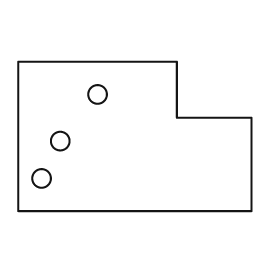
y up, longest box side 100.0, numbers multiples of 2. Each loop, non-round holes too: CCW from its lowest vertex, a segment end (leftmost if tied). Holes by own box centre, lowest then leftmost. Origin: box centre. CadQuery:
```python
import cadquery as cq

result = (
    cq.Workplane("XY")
    .moveTo(-50.0, -32.0)
    .lineTo(50.0, -32.0)
    .lineTo(50.0, 8.0)
    .lineTo(18.0, 8.0)
    .lineTo(18.0, 32.0)
    .lineTo(-50.0, 32.0)
    .close()
    .moveTo(-40.0, -18.0)
    .circle(4.0)
    .moveTo(-32.0, -2.0)
    .circle(4.0)
    .moveTo(-16.0, 18.0)
    .circle(4.0)
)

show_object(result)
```